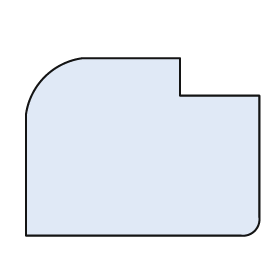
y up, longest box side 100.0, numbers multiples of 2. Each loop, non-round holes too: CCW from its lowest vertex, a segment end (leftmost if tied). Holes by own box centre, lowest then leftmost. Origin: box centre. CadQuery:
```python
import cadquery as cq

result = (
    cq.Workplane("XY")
    .moveTo(-50.0, -38.0)
    .lineTo(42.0, -38.0)
    .threePointArc((48.0, -36.0), (50.0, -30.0))
    .lineTo(50.0, 22.0)
    .lineTo(16.0, 22.0)
    .lineTo(16.0, 38.0)
    .lineTo(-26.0, 38.0)
    .threePointArc((-42.0, 30.0), (-50.0, 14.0))
    .close()
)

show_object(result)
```